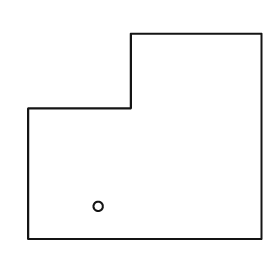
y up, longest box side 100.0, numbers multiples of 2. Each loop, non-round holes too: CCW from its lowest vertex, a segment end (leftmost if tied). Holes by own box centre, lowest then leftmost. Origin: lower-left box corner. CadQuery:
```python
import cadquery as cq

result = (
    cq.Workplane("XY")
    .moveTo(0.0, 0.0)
    .lineTo(100.0, 0.0)
    .lineTo(100.0, 88.0)
    .lineTo(44.0, 88.0)
    .lineTo(44.0, 56.0)
    .lineTo(0.0, 56.0)
    .close()
    .moveTo(30.0, 14.0)
    .circle(2.0)
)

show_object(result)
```